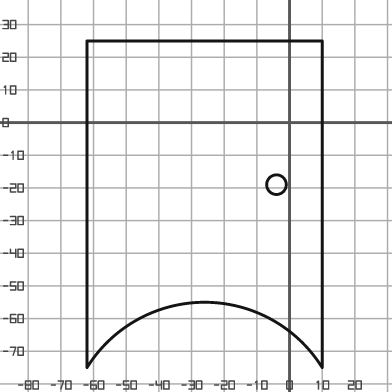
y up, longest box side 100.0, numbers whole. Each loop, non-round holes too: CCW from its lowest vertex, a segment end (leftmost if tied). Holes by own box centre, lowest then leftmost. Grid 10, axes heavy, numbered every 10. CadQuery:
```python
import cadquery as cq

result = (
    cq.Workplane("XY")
    .moveTo(-62.0, -75.0)
    .threePointArc((-26.0, -55.0), (10.0, -75.0))
    .lineTo(10.0, 25.0)
    .lineTo(-62.0, 25.0)
    .close()
    .moveTo(-4.0, -19.0)
    .circle(3.0)
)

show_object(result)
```